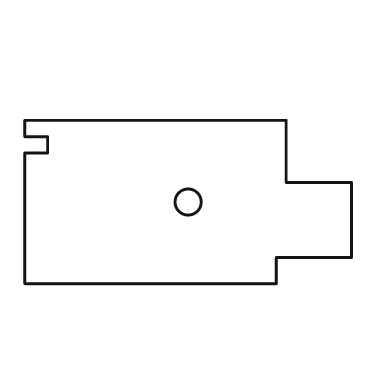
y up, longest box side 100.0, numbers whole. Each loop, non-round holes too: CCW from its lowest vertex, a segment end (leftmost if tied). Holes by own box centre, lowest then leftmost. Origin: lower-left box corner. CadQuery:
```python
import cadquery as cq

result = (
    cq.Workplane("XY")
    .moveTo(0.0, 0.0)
    .lineTo(77.0, 0.0)
    .lineTo(77.0, 8.0)
    .lineTo(100.0, 8.0)
    .lineTo(100.0, 31.0)
    .lineTo(80.0, 31.0)
    .lineTo(80.0, 50.0)
    .lineTo(0.0, 50.0)
    .lineTo(0.0, 45.0)
    .lineTo(7.0, 45.0)
    .lineTo(7.0, 40.0)
    .lineTo(0.0, 40.0)
    .close()
    .moveTo(50.0, 25.0)
    .circle(4.0)
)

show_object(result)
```